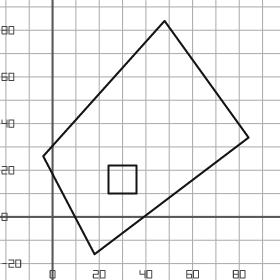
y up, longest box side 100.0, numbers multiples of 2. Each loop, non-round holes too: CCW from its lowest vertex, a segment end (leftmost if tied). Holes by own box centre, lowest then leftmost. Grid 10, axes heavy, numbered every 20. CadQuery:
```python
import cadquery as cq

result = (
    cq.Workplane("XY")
    .moveTo(18.0, -16.0)
    .lineTo(84.0, 34.0)
    .lineTo(48.0, 84.0)
    .lineTo(-4.0, 26.0)
    .close()
    .moveTo(24.0, 10.0)
    .lineTo(36.0, 10.0)
    .lineTo(36.0, 22.0)
    .lineTo(24.0, 22.0)
    .close()
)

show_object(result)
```